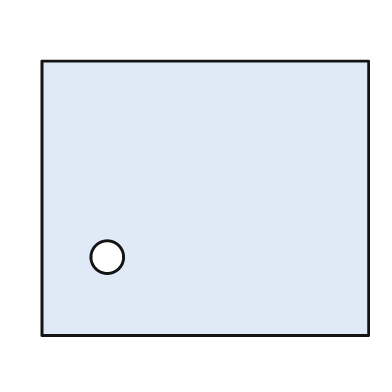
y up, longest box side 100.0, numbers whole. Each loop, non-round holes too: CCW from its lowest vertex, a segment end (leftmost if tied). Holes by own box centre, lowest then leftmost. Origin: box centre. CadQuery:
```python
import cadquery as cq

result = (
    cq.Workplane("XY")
    .moveTo(-50.0, -42.0)
    .lineTo(50.0, -42.0)
    .lineTo(50.0, 42.0)
    .lineTo(-50.0, 42.0)
    .close()
    .moveTo(-30.0, -18.0)
    .circle(5.0)
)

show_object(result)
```